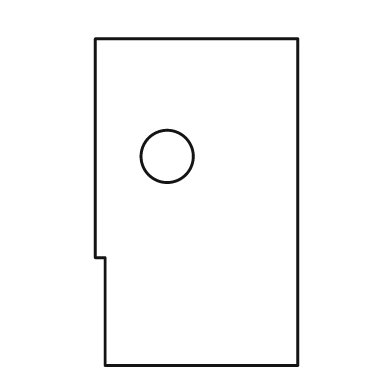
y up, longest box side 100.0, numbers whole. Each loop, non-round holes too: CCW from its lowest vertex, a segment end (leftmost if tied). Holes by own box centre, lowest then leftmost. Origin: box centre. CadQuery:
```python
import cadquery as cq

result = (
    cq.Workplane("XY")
    .moveTo(-28.0, -50.0)
    .lineTo(31.0, -50.0)
    .lineTo(31.0, 50.0)
    .lineTo(-31.0, 50.0)
    .lineTo(-31.0, -17.0)
    .lineTo(-28.0, -17.0)
    .close()
    .moveTo(-9.0, 14.0)
    .circle(8.0)
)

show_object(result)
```